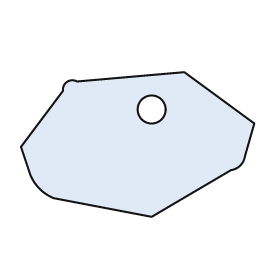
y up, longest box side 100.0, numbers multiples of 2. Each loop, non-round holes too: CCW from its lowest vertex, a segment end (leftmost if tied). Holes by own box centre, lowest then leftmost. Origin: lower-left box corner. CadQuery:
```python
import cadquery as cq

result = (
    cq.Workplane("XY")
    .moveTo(56.0, 0.0)
    .lineTo(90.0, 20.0)
    .threePointArc((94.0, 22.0), (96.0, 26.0))
    .lineTo(100.0, 40.0)
    .lineTo(70.0, 62.0)
    .lineTo(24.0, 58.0)
    .threePointArc((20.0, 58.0), (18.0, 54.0))
    .lineTo(0.0, 30.0)
    .lineTo(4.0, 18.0)
    .threePointArc((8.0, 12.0), (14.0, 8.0))
    .close()
    .moveTo(56.0, 46.0)
    .circle(6.0)
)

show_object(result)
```